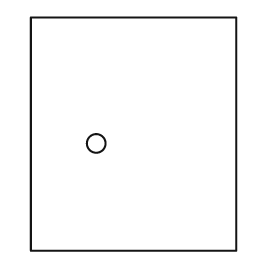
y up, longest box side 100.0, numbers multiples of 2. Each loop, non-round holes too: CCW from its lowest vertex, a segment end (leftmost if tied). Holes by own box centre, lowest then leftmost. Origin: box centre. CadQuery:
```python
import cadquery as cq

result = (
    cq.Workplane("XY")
    .moveTo(-44.0, -50.0)
    .lineTo(44.0, -50.0)
    .lineTo(44.0, 50.0)
    .lineTo(-44.0, 50.0)
    .close()
    .moveTo(-16.0, -4.0)
    .circle(4.0)
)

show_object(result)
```